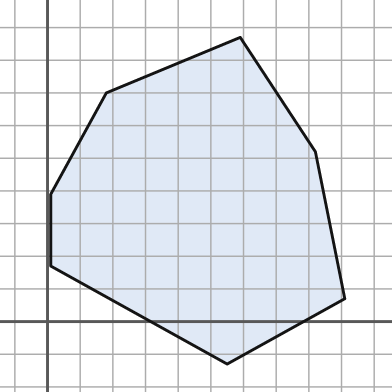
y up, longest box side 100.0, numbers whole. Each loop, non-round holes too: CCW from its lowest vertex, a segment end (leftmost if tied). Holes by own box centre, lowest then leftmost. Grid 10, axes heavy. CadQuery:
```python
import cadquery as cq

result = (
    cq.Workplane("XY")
    .moveTo(55.0, -13.0)
    .lineTo(91.0, 7.0)
    .lineTo(82.0, 52.0)
    .lineTo(59.0, 87.0)
    .lineTo(18.0, 70.0)
    .lineTo(1.0, 39.0)
    .lineTo(1.0, 17.0)
    .close()
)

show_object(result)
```